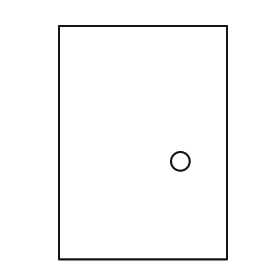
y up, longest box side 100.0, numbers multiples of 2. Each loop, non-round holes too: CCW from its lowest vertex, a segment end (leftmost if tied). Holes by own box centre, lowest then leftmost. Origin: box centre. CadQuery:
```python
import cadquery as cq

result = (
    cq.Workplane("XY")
    .moveTo(-36.0, -50.0)
    .lineTo(36.0, -50.0)
    .lineTo(36.0, 50.0)
    .lineTo(-36.0, 50.0)
    .close()
    .moveTo(16.0, -8.0)
    .circle(4.0)
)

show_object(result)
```